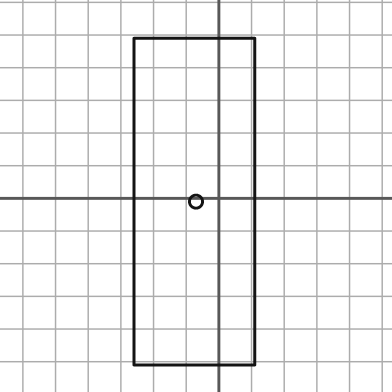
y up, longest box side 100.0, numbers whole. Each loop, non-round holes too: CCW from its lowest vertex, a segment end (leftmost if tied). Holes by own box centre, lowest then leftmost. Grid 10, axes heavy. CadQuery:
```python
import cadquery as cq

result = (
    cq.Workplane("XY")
    .moveTo(-26.0, -51.0)
    .lineTo(11.0, -51.0)
    .lineTo(11.0, 49.0)
    .lineTo(-26.0, 49.0)
    .close()
    .moveTo(-7.0, -1.0)
    .circle(2.0)
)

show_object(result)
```